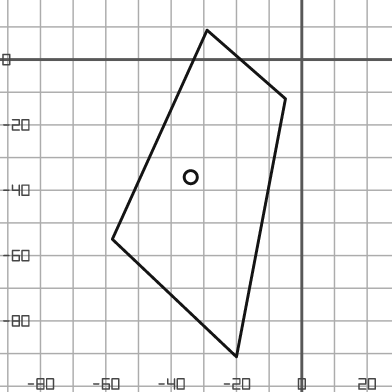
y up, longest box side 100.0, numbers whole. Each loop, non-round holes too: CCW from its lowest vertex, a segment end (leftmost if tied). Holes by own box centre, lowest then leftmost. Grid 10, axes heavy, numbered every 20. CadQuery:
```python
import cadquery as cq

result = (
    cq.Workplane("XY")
    .moveTo(-20.0, -91.0)
    .lineTo(-5.0, -12.0)
    .lineTo(-29.0, 9.0)
    .lineTo(-58.0, -55.0)
    .close()
    .moveTo(-34.0, -36.0)
    .circle(2.0)
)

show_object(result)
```